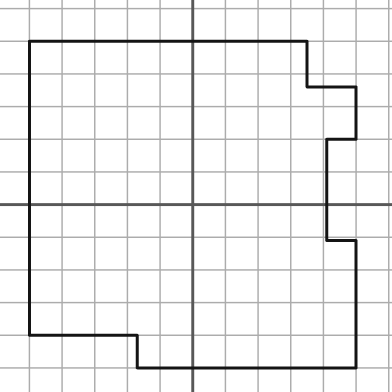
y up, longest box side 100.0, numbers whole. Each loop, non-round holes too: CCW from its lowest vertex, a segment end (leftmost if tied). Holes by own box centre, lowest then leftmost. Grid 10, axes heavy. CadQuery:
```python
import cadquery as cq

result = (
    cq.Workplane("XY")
    .moveTo(-17.0, -50.0)
    .lineTo(50.0, -50.0)
    .lineTo(50.0, -11.0)
    .lineTo(41.0, -11.0)
    .lineTo(41.0, 20.0)
    .lineTo(50.0, 20.0)
    .lineTo(50.0, 36.0)
    .lineTo(35.0, 36.0)
    .lineTo(35.0, 50.0)
    .lineTo(-50.0, 50.0)
    .lineTo(-50.0, -40.0)
    .lineTo(-17.0, -40.0)
    .close()
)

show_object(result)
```